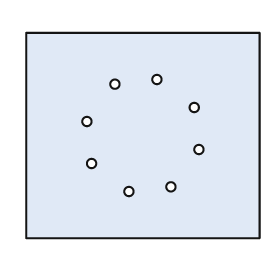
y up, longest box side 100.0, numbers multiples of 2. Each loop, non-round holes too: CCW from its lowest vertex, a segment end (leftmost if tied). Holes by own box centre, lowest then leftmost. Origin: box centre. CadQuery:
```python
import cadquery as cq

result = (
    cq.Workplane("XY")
    .moveTo(-50.0, -44.0)
    .lineTo(50.0, -44.0)
    .lineTo(50.0, 44.0)
    .lineTo(-50.0, 44.0)
    .close()
    .moveTo(-6.0, -24.0)
    .circle(2.0)
    .moveTo(12.0, -22.0)
    .circle(2.0)
    .moveTo(-22.0, -12.0)
    .circle(2.0)
    .moveTo(24.0, -6.0)
    .circle(2.0)
    .moveTo(-24.0, 6.0)
    .circle(2.0)
    .moveTo(22.0, 12.0)
    .circle(2.0)
    .moveTo(-12.0, 22.0)
    .circle(2.0)
    .moveTo(6.0, 24.0)
    .circle(2.0)
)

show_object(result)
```